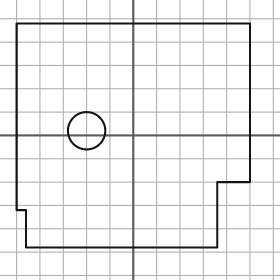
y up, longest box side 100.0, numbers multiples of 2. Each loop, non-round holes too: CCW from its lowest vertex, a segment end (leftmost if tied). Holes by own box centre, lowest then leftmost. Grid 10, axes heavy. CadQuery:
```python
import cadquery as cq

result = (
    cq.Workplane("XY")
    .moveTo(-46.0, -48.0)
    .lineTo(36.0, -48.0)
    .lineTo(36.0, -20.0)
    .lineTo(50.0, -20.0)
    .lineTo(50.0, 48.0)
    .lineTo(-50.0, 48.0)
    .lineTo(-50.0, -32.0)
    .lineTo(-46.0, -32.0)
    .close()
    .moveTo(-20.0, 2.0)
    .circle(8.0)
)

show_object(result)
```